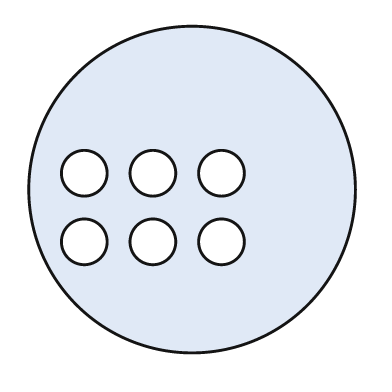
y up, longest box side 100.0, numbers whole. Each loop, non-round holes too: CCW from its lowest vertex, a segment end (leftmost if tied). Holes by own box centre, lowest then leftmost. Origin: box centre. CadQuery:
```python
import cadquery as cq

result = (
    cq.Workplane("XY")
    .moveTo(0.0, 0.0)
    .circle(50.0)
    .moveTo(-33.0, -16.0)
    .circle(7.0)
    .moveTo(-12.0, -16.0)
    .circle(7.0)
    .moveTo(9.0, -16.0)
    .circle(7.0)
    .moveTo(-33.0, 5.0)
    .circle(7.0)
    .moveTo(-12.0, 5.0)
    .circle(7.0)
    .moveTo(9.0, 5.0)
    .circle(7.0)
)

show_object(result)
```